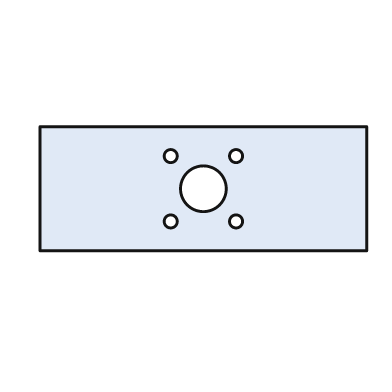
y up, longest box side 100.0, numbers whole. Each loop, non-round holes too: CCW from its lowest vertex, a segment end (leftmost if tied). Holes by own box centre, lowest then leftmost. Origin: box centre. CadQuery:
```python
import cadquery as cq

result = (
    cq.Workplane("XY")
    .moveTo(-50.0, -19.0)
    .lineTo(50.0, -19.0)
    .lineTo(50.0, 19.0)
    .lineTo(-50.0, 19.0)
    .close()
    .moveTo(-10.0, -10.0)
    .circle(2.0)
    .moveTo(10.0, -10.0)
    .circle(2.0)
    .moveTo(0.0, 0.0)
    .circle(7.0)
    .moveTo(-10.0, 10.0)
    .circle(2.0)
    .moveTo(10.0, 10.0)
    .circle(2.0)
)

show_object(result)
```